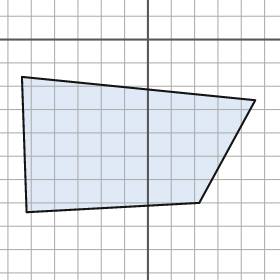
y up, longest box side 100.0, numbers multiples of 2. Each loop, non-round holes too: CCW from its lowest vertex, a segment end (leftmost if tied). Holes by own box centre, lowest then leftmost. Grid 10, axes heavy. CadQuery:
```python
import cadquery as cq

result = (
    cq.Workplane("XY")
    .moveTo(-52.0, -74.0)
    .lineTo(22.0, -70.0)
    .lineTo(46.0, -26.0)
    .lineTo(-54.0, -16.0)
    .close()
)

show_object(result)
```